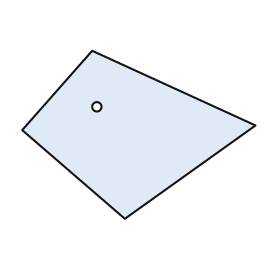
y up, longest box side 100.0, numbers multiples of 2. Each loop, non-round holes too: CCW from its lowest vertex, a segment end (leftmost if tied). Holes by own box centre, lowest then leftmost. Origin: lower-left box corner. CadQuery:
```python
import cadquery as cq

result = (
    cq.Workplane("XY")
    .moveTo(44.0, 0.0)
    .lineTo(100.0, 40.0)
    .lineTo(30.0, 72.0)
    .lineTo(0.0, 38.0)
    .close()
    .moveTo(32.0, 48.0)
    .circle(2.0)
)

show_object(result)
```